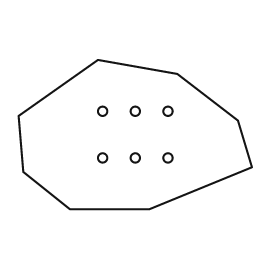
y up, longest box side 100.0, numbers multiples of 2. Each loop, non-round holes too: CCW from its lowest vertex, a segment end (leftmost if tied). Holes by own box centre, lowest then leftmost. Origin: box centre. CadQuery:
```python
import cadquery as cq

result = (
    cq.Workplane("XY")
    .moveTo(-28.0, -32.0)
    .lineTo(6.0, -32.0)
    .lineTo(50.0, -14.0)
    .lineTo(44.0, 6.0)
    .lineTo(18.0, 26.0)
    .lineTo(-16.0, 32.0)
    .lineTo(-50.0, 8.0)
    .lineTo(-48.0, -16.0)
    .close()
    .moveTo(-14.0, -10.0)
    .circle(2.0)
    .moveTo(0.0, -10.0)
    .circle(2.0)
    .moveTo(14.0, -10.0)
    .circle(2.0)
    .moveTo(-14.0, 10.0)
    .circle(2.0)
    .moveTo(0.0, 10.0)
    .circle(2.0)
    .moveTo(14.0, 10.0)
    .circle(2.0)
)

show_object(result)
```